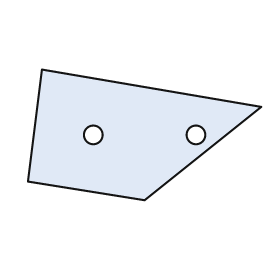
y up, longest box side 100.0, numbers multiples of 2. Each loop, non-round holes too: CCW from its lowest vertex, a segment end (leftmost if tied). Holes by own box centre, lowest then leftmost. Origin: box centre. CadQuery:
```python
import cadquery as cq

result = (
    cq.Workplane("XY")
    .moveTo(0.0, -28.0)
    .lineTo(50.0, 12.0)
    .lineTo(-44.0, 28.0)
    .lineTo(-50.0, -20.0)
    .close()
    .moveTo(-22.0, 0.0)
    .circle(4.0)
    .moveTo(22.0, 0.0)
    .circle(4.0)
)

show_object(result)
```